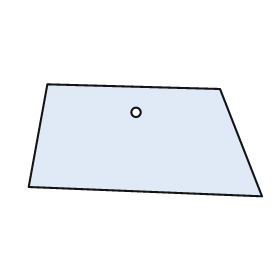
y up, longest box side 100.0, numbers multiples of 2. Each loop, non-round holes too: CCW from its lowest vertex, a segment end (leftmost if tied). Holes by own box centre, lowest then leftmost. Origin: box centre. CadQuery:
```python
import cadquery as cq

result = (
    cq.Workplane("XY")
    .moveTo(50.0, -24.0)
    .lineTo(32.0, 22.0)
    .lineTo(-42.0, 24.0)
    .lineTo(-50.0, -20.0)
    .close()
    .moveTo(-4.0, 12.0)
    .circle(2.0)
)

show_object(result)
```